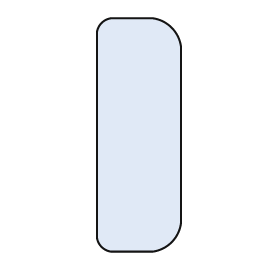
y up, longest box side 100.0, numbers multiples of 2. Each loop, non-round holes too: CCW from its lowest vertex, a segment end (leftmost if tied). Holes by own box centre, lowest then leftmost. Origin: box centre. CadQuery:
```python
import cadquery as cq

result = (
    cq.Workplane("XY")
    .moveTo(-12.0, -50.0)
    .lineTo(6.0, -50.0)
    .threePointArc((14.0, -46.0), (18.0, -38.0))
    .lineTo(18.0, 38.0)
    .threePointArc((14.0, 46.0), (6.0, 50.0))
    .lineTo(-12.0, 50.0)
    .threePointArc((-16.0, 48.0), (-18.0, 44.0))
    .lineTo(-18.0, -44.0)
    .threePointArc((-16.0, -48.0), (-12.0, -50.0))
    .close()
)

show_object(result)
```